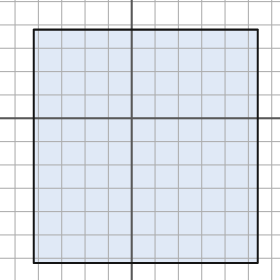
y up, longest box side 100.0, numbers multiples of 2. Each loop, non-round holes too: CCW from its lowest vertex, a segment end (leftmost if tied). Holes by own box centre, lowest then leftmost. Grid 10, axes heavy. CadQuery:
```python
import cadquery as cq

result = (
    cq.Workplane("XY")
    .moveTo(-42.0, -62.0)
    .lineTo(54.0, -62.0)
    .lineTo(54.0, 38.0)
    .lineTo(-42.0, 38.0)
    .close()
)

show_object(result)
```